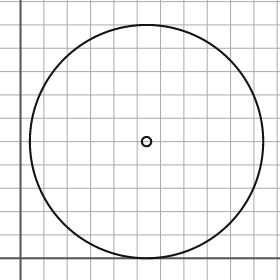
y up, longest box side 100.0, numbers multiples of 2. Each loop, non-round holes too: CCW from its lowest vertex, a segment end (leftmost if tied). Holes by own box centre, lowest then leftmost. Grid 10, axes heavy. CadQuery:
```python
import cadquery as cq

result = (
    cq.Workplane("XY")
    .moveTo(54.0, 50.0)
    .circle(50.0)
    .moveTo(54.0, 50.0)
    .circle(2.0)
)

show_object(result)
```